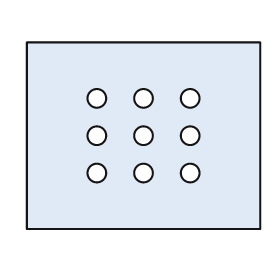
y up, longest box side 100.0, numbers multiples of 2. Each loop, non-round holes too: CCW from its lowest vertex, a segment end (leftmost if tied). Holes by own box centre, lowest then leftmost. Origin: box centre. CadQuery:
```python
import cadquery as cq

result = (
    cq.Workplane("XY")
    .moveTo(-50.0, -40.0)
    .lineTo(50.0, -40.0)
    .lineTo(50.0, 40.0)
    .lineTo(-50.0, 40.0)
    .close()
    .moveTo(-20.0, -16.0)
    .circle(4.0)
    .moveTo(0.0, -16.0)
    .circle(4.0)
    .moveTo(20.0, -16.0)
    .circle(4.0)
    .moveTo(-20.0, 0.0)
    .circle(4.0)
    .moveTo(0.0, 0.0)
    .circle(4.0)
    .moveTo(20.0, 0.0)
    .circle(4.0)
    .moveTo(-20.0, 16.0)
    .circle(4.0)
    .moveTo(0.0, 16.0)
    .circle(4.0)
    .moveTo(20.0, 16.0)
    .circle(4.0)
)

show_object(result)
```